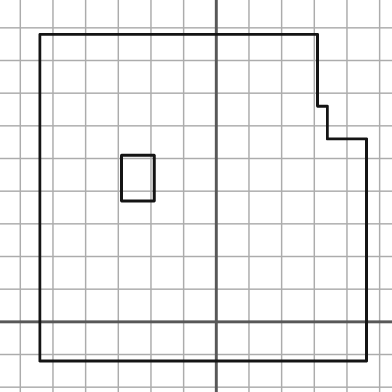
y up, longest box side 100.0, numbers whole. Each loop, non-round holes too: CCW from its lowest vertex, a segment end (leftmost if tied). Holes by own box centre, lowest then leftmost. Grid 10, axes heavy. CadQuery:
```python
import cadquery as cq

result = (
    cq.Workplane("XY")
    .moveTo(-54.0, -12.0)
    .lineTo(46.0, -12.0)
    .lineTo(46.0, 56.0)
    .lineTo(34.0, 56.0)
    .lineTo(34.0, 66.0)
    .lineTo(31.0, 66.0)
    .lineTo(31.0, 88.0)
    .lineTo(-54.0, 88.0)
    .close()
    .moveTo(-29.0, 37.0)
    .lineTo(-19.0, 37.0)
    .lineTo(-19.0, 51.0)
    .lineTo(-29.0, 51.0)
    .close()
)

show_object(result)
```